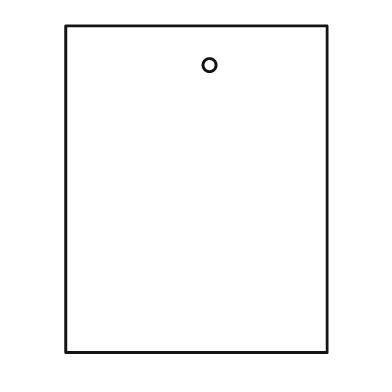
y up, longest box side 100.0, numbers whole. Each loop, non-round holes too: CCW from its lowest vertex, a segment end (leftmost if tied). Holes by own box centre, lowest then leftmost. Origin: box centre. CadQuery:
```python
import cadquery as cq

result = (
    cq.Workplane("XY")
    .moveTo(-40.0, -50.0)
    .lineTo(40.0, -50.0)
    .lineTo(40.0, 50.0)
    .lineTo(-40.0, 50.0)
    .close()
    .moveTo(4.0, 38.0)
    .circle(2.0)
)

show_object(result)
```